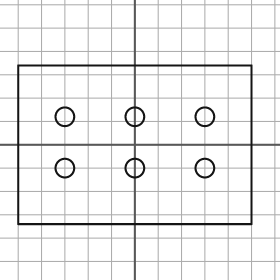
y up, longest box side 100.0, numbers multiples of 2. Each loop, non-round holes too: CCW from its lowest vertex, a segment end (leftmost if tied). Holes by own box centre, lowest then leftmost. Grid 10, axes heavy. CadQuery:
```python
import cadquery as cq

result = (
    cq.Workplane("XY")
    .moveTo(-50.0, -34.0)
    .lineTo(50.0, -34.0)
    .lineTo(50.0, 34.0)
    .lineTo(-50.0, 34.0)
    .close()
    .moveTo(-30.0, -10.0)
    .circle(4.0)
    .moveTo(0.0, -10.0)
    .circle(4.0)
    .moveTo(30.0, -10.0)
    .circle(4.0)
    .moveTo(-30.0, 12.0)
    .circle(4.0)
    .moveTo(0.0, 12.0)
    .circle(4.0)
    .moveTo(30.0, 12.0)
    .circle(4.0)
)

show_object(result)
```